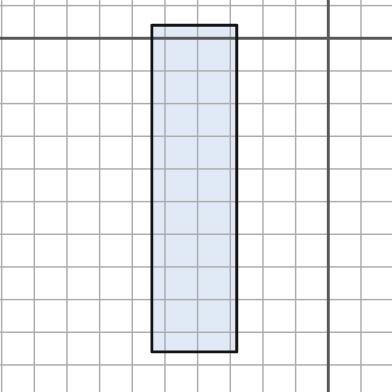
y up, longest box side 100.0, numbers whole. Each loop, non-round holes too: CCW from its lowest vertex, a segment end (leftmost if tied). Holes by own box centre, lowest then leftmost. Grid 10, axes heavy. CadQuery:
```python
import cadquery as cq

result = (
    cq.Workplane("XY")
    .moveTo(-54.0, -96.0)
    .lineTo(-28.0, -96.0)
    .lineTo(-28.0, 4.0)
    .lineTo(-54.0, 4.0)
    .close()
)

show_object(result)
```